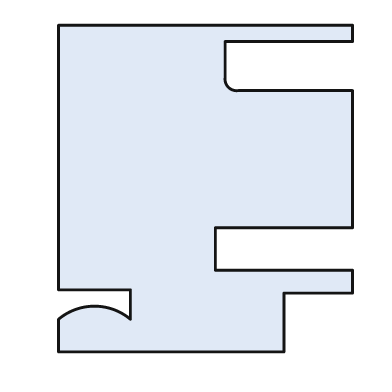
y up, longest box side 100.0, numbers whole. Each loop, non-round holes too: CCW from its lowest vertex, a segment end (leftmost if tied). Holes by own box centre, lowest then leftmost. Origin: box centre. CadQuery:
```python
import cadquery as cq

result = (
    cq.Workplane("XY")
    .moveTo(-45.0, -50.0)
    .lineTo(24.0, -50.0)
    .lineTo(24.0, -32.0)
    .lineTo(45.0, -32.0)
    .lineTo(45.0, -25.0)
    .lineTo(3.0, -25.0)
    .lineTo(3.0, -12.0)
    .lineTo(45.0, -12.0)
    .lineTo(45.0, 30.0)
    .lineTo(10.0, 30.0)
    .threePointArc((7.0, 31.0), (6.0, 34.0))
    .lineTo(6.0, 45.0)
    .lineTo(45.0, 45.0)
    .lineTo(45.0, 50.0)
    .lineTo(-45.0, 50.0)
    .lineTo(-45.0, -31.0)
    .lineTo(-23.0, -31.0)
    .lineTo(-23.0, -40.0)
    .threePointArc((-34.0, -36.0), (-45.0, -40.0))
    .close()
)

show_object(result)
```